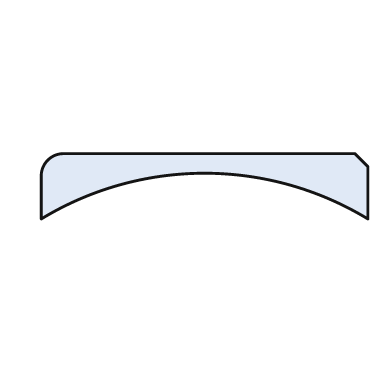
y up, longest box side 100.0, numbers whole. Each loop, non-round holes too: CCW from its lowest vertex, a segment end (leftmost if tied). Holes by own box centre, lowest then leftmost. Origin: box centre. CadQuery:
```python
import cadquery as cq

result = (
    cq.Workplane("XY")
    .moveTo(-50.0, -10.0)
    .threePointArc((0.0, 4.0), (50.0, -10.0))
    .lineTo(50.0, 6.0)
    .lineTo(46.0, 10.0)
    .lineTo(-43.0, 10.0)
    .threePointArc((-48.0, 8.0), (-50.0, 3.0))
    .close()
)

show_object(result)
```